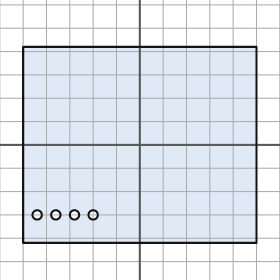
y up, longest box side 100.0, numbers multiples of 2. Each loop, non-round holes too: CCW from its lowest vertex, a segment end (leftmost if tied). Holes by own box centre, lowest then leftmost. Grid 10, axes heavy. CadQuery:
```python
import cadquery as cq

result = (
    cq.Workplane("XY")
    .moveTo(-50.0, -42.0)
    .lineTo(50.0, -42.0)
    .lineTo(50.0, 42.0)
    .lineTo(-50.0, 42.0)
    .close()
    .moveTo(-44.0, -30.0)
    .circle(2.0)
    .moveTo(-36.0, -30.0)
    .circle(2.0)
    .moveTo(-28.0, -30.0)
    .circle(2.0)
    .moveTo(-20.0, -30.0)
    .circle(2.0)
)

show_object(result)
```